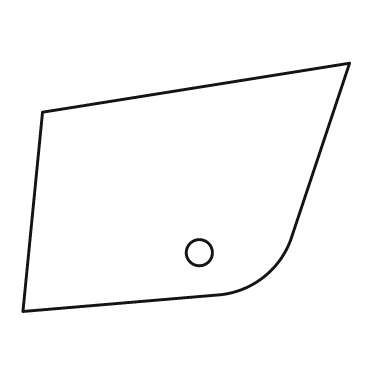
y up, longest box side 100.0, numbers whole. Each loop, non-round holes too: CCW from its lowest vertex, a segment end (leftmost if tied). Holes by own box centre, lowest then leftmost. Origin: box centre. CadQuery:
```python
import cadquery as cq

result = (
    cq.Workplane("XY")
    .moveTo(-50.0, -38.0)
    .lineTo(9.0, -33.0)
    .threePointArc((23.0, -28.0), (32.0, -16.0))
    .lineTo(50.0, 38.0)
    .lineTo(-44.0, 23.0)
    .close()
    .moveTo(4.0, -20.0)
    .circle(4.0)
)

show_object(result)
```